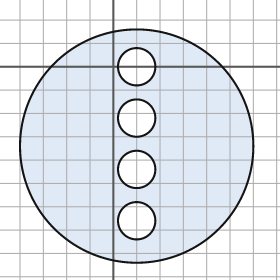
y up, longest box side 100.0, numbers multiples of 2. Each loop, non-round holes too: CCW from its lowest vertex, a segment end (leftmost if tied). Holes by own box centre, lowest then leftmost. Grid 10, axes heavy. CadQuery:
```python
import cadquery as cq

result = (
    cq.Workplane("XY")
    .moveTo(10.0, -34.0)
    .circle(50.0)
    .moveTo(10.0, -66.0)
    .circle(8.0)
    .moveTo(10.0, -44.0)
    .circle(8.0)
    .moveTo(10.0, -22.0)
    .circle(8.0)
    .moveTo(10.0, 0.0)
    .circle(8.0)
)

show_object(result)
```